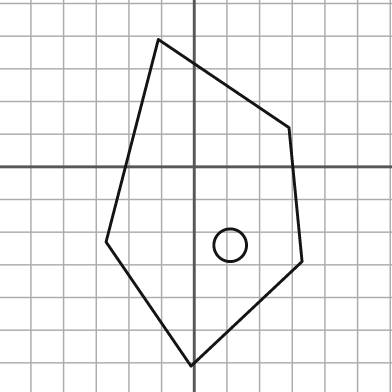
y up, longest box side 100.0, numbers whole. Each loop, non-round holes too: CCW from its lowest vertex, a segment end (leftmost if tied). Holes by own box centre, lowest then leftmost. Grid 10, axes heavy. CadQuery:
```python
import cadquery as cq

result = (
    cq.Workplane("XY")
    .moveTo(-1.0, -61.0)
    .lineTo(33.0, -29.0)
    .lineTo(29.0, 12.0)
    .lineTo(-11.0, 39.0)
    .lineTo(-27.0, -23.0)
    .close()
    .moveTo(11.0, -24.0)
    .circle(5.0)
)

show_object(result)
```